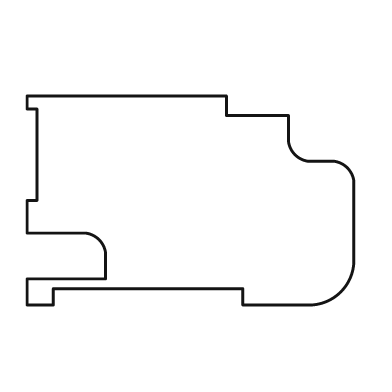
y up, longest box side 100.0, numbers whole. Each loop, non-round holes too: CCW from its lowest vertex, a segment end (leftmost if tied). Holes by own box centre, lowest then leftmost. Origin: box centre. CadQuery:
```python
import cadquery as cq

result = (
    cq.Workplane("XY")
    .moveTo(-50.0, -32.0)
    .lineTo(-42.0, -32.0)
    .lineTo(-42.0, -27.0)
    .lineTo(16.0, -27.0)
    .lineTo(16.0, -32.0)
    .lineTo(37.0, -32.0)
    .threePointArc((46.0, -28.0), (50.0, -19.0))
    .lineTo(50.0, 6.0)
    .threePointArc((48.0, 10.0), (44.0, 12.0))
    .lineTo(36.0, 12.0)
    .threePointArc((32.0, 14.0), (30.0, 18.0))
    .lineTo(30.0, 26.0)
    .lineTo(11.0, 26.0)
    .lineTo(11.0, 32.0)
    .lineTo(-50.0, 32.0)
    .lineTo(-50.0, 28.0)
    .lineTo(-47.0, 28.0)
    .lineTo(-47.0, 0.0)
    .lineTo(-50.0, 0.0)
    .lineTo(-50.0, -10.0)
    .lineTo(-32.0, -10.0)
    .threePointArc((-28.0, -12.0), (-26.0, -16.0))
    .lineTo(-26.0, -24.0)
    .lineTo(-50.0, -24.0)
    .close()
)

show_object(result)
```